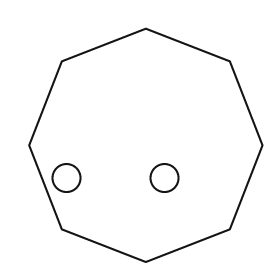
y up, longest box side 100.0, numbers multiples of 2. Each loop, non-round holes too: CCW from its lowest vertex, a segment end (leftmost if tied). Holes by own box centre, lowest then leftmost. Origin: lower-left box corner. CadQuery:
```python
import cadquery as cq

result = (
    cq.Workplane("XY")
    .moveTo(50.0, 0.0)
    .lineTo(86.0, 14.0)
    .lineTo(100.0, 50.0)
    .lineTo(86.0, 86.0)
    .lineTo(50.0, 100.0)
    .lineTo(14.0, 86.0)
    .lineTo(0.0, 50.0)
    .lineTo(14.0, 14.0)
    .close()
    .moveTo(16.0, 36.0)
    .circle(6.0)
    .moveTo(58.0, 36.0)
    .circle(6.0)
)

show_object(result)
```